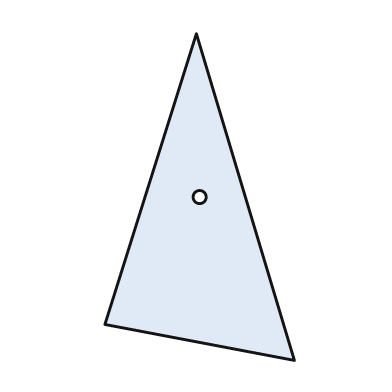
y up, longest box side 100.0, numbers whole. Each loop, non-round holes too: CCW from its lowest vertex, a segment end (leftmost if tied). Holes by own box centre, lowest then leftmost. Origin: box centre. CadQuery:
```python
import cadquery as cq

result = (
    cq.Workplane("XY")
    .moveTo(29.0, -50.0)
    .lineTo(-1.0, 50.0)
    .lineTo(-29.0, -39.0)
    .close()
    .moveTo(0.0, 0.0)
    .circle(2.0)
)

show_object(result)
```